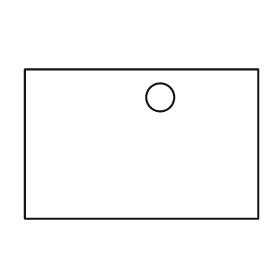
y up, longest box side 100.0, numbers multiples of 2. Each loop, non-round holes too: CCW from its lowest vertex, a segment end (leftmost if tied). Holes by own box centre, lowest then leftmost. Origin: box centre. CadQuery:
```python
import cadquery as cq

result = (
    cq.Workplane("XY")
    .moveTo(-50.0, -32.0)
    .lineTo(50.0, -32.0)
    .lineTo(50.0, 32.0)
    .lineTo(-50.0, 32.0)
    .close()
    .moveTo(8.0, 20.0)
    .circle(6.0)
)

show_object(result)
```